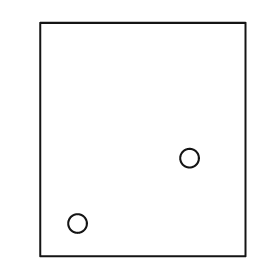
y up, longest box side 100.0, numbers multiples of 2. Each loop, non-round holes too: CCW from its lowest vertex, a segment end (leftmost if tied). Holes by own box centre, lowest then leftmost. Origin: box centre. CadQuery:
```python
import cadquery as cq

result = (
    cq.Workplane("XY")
    .moveTo(-44.0, -50.0)
    .lineTo(44.0, -50.0)
    .lineTo(44.0, 50.0)
    .lineTo(-44.0, 50.0)
    .close()
    .moveTo(-28.0, -36.0)
    .circle(4.0)
    .moveTo(20.0, -8.0)
    .circle(4.0)
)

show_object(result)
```